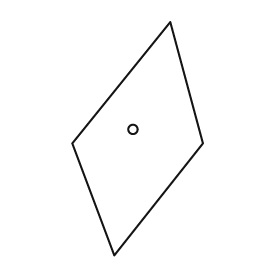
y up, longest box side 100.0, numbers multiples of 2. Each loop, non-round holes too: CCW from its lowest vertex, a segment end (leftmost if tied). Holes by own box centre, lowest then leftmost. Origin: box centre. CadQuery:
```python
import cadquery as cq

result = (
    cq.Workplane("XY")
    .moveTo(-10.0, -50.0)
    .lineTo(28.0, -2.0)
    .lineTo(14.0, 50.0)
    .lineTo(-28.0, -2.0)
    .close()
    .moveTo(-2.0, 4.0)
    .circle(2.0)
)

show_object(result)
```